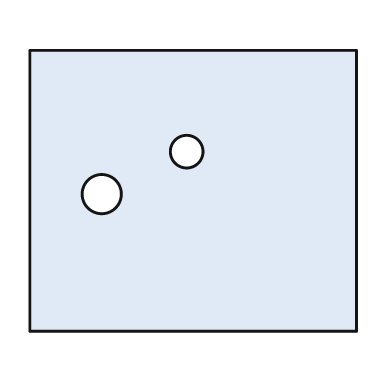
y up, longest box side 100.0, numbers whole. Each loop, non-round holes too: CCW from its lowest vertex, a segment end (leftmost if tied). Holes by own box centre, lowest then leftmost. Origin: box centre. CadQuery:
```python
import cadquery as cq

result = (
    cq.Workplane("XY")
    .moveTo(-50.0, -43.0)
    .lineTo(50.0, -43.0)
    .lineTo(50.0, 43.0)
    .lineTo(-50.0, 43.0)
    .close()
    .moveTo(-28.0, -1.0)
    .circle(6.0)
    .moveTo(-2.0, 12.0)
    .circle(5.0)
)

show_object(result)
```